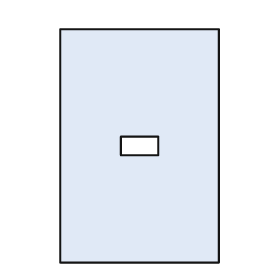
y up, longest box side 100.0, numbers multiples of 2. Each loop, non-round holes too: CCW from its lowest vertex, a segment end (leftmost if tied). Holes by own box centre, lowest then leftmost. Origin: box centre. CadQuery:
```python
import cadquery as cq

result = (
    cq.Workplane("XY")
    .moveTo(-34.0, -50.0)
    .lineTo(34.0, -50.0)
    .lineTo(34.0, 50.0)
    .lineTo(-34.0, 50.0)
    .close()
    .moveTo(-8.0, -4.0)
    .lineTo(8.0, -4.0)
    .lineTo(8.0, 4.0)
    .lineTo(-8.0, 4.0)
    .close()
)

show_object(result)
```